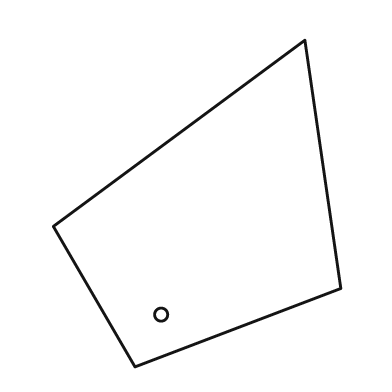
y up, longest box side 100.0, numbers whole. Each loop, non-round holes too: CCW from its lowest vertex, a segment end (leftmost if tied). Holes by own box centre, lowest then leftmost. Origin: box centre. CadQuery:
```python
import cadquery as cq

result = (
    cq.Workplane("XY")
    .moveTo(-19.0, -50.0)
    .lineTo(44.0, -26.0)
    .lineTo(33.0, 50.0)
    .lineTo(-44.0, -7.0)
    .close()
    .moveTo(-11.0, -34.0)
    .circle(2.0)
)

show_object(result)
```